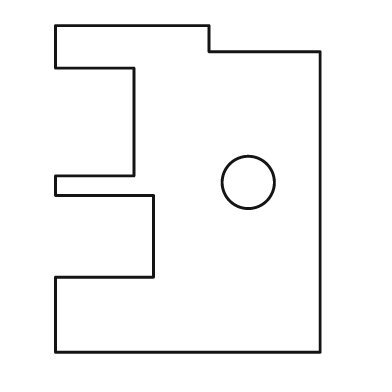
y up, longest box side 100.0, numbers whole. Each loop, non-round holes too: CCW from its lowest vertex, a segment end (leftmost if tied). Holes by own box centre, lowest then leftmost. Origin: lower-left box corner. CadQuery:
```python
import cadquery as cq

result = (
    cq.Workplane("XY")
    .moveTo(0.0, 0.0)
    .lineTo(81.0, 0.0)
    .lineTo(81.0, 92.0)
    .lineTo(47.0, 92.0)
    .lineTo(47.0, 100.0)
    .lineTo(0.0, 100.0)
    .lineTo(0.0, 87.0)
    .lineTo(24.0, 87.0)
    .lineTo(24.0, 54.0)
    .lineTo(0.0, 54.0)
    .lineTo(0.0, 48.0)
    .lineTo(30.0, 48.0)
    .lineTo(30.0, 23.0)
    .lineTo(0.0, 23.0)
    .close()
    .moveTo(59.0, 52.0)
    .circle(8.0)
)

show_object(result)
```